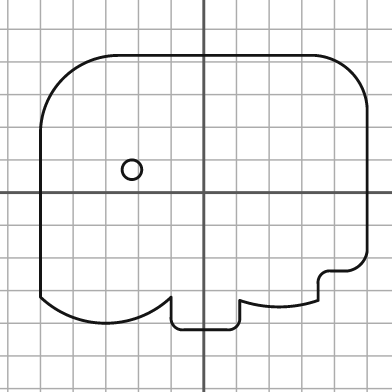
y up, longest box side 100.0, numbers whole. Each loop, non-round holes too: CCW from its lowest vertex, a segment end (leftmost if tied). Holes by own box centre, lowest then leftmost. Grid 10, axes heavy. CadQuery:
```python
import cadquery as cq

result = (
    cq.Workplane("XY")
    .moveTo(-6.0, -42.0)
    .lineTo(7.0, -42.0)
    .threePointArc((10.0, -41.0), (11.0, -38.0))
    .lineTo(11.0, -33.0)
    .threePointArc((23.0, -35.0), (35.0, -33.0))
    .lineTo(35.0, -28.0)
    .threePointArc((36.0, -25.0), (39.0, -24.0))
    .lineTo(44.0, -24.0)
    .threePointArc((48.0, -22.0), (50.0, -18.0))
    .lineTo(50.0, 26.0)
    .threePointArc((45.0, 37.0), (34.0, 42.0))
    .lineTo(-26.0, 42.0)
    .threePointArc((-43.0, 35.0), (-50.0, 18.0))
    .lineTo(-50.0, -32.0)
    .threePointArc((-30.0, -40.0), (-10.0, -32.0))
    .lineTo(-10.0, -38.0)
    .threePointArc((-9.0, -41.0), (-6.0, -42.0))
    .close()
    .moveTo(-22.0, 7.0)
    .circle(3.0)
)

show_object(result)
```